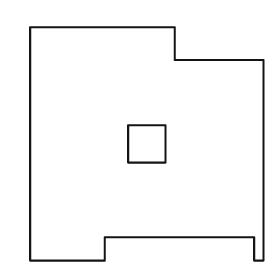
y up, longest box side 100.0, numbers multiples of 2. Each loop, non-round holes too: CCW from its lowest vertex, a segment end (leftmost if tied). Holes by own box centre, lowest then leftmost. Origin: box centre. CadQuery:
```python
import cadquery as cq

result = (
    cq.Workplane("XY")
    .moveTo(-50.0, -50.0)
    .lineTo(-18.0, -50.0)
    .lineTo(-18.0, -40.0)
    .lineTo(46.0, -40.0)
    .lineTo(46.0, -50.0)
    .lineTo(50.0, -50.0)
    .lineTo(50.0, 36.0)
    .lineTo(12.0, 36.0)
    .lineTo(12.0, 50.0)
    .lineTo(-50.0, 50.0)
    .close()
    .moveTo(-8.0, -8.0)
    .lineTo(8.0, -8.0)
    .lineTo(8.0, 8.0)
    .lineTo(-8.0, 8.0)
    .close()
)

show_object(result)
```